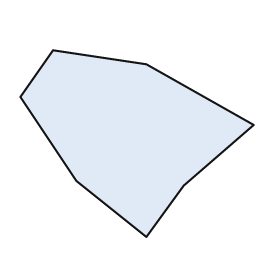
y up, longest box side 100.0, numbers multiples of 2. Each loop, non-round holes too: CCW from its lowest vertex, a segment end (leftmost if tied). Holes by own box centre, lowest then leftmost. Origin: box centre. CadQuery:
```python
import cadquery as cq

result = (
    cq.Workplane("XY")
    .moveTo(4.0, -40.0)
    .lineTo(20.0, -18.0)
    .lineTo(50.0, 8.0)
    .lineTo(4.0, 34.0)
    .lineTo(-36.0, 40.0)
    .lineTo(-50.0, 20.0)
    .lineTo(-26.0, -16.0)
    .close()
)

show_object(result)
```